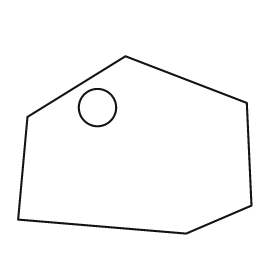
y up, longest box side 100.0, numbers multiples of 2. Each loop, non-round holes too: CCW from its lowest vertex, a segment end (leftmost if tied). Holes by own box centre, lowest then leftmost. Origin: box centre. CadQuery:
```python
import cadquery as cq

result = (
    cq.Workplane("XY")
    .moveTo(22.0, -38.0)
    .lineTo(50.0, -26.0)
    .lineTo(48.0, 18.0)
    .lineTo(-4.0, 38.0)
    .lineTo(-46.0, 12.0)
    .lineTo(-50.0, -32.0)
    .close()
    .moveTo(-16.0, 16.0)
    .circle(8.0)
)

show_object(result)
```